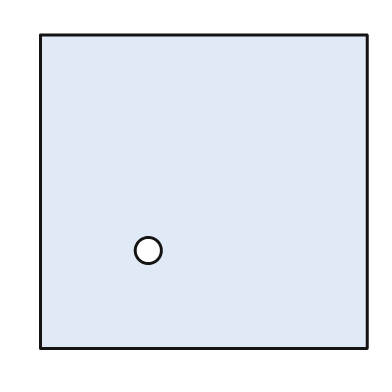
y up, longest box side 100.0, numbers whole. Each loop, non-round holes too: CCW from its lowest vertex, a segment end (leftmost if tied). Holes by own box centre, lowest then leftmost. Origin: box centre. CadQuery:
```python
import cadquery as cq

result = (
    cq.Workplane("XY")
    .moveTo(-50.0, -48.0)
    .lineTo(50.0, -48.0)
    .lineTo(50.0, 48.0)
    .lineTo(-50.0, 48.0)
    .close()
    .moveTo(-17.0, -18.0)
    .circle(4.0)
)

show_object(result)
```